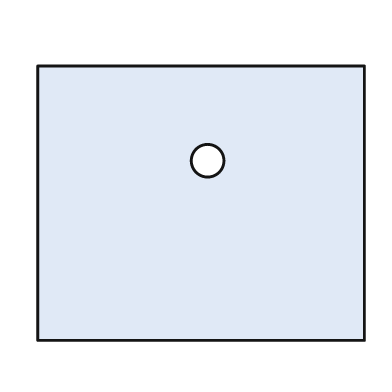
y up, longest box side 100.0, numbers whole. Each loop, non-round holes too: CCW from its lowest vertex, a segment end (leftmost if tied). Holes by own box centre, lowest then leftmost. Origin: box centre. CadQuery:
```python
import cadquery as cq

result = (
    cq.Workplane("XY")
    .moveTo(-50.0, -42.0)
    .lineTo(50.0, -42.0)
    .lineTo(50.0, 42.0)
    .lineTo(-50.0, 42.0)
    .close()
    .moveTo(2.0, 13.0)
    .circle(5.0)
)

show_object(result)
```